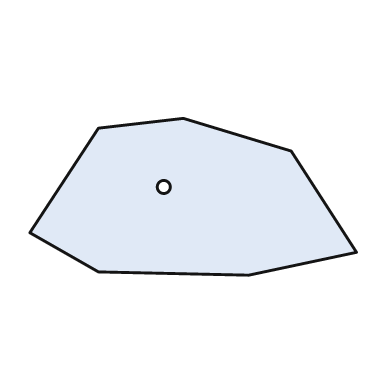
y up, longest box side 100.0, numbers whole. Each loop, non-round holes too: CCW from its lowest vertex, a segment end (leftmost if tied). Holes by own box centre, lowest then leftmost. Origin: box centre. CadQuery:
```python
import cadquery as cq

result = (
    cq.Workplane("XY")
    .moveTo(17.0, -24.0)
    .lineTo(50.0, -17.0)
    .lineTo(30.0, 14.0)
    .lineTo(-3.0, 24.0)
    .lineTo(-29.0, 21.0)
    .lineTo(-50.0, -11.0)
    .lineTo(-29.0, -23.0)
    .close()
    .moveTo(-9.0, 3.0)
    .circle(2.0)
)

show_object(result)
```